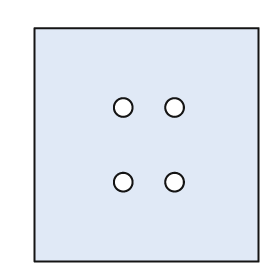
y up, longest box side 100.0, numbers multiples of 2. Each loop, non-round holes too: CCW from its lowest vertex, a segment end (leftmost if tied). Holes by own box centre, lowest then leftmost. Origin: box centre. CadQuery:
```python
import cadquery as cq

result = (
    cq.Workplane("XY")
    .moveTo(-48.0, -50.0)
    .lineTo(48.0, -50.0)
    .lineTo(48.0, 50.0)
    .lineTo(-48.0, 50.0)
    .close()
    .moveTo(-10.0, -16.0)
    .circle(4.0)
    .moveTo(12.0, -16.0)
    .circle(4.0)
    .moveTo(-10.0, 16.0)
    .circle(4.0)
    .moveTo(12.0, 16.0)
    .circle(4.0)
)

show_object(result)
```